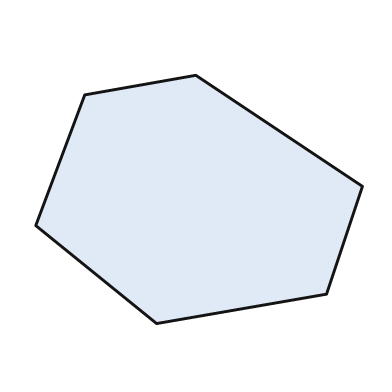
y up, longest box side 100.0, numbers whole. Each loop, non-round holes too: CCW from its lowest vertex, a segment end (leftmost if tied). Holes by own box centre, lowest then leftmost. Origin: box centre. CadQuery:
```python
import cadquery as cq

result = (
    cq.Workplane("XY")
    .moveTo(-13.0, -38.0)
    .lineTo(39.0, -29.0)
    .lineTo(50.0, 4.0)
    .lineTo(-1.0, 38.0)
    .lineTo(-35.0, 32.0)
    .lineTo(-50.0, -8.0)
    .close()
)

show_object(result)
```